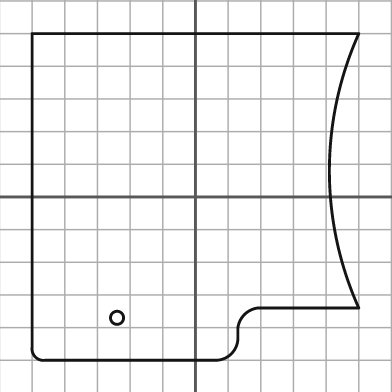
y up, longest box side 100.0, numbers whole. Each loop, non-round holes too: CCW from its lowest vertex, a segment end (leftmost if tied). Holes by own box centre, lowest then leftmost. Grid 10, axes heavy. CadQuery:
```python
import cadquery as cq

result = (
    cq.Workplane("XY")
    .moveTo(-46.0, -50.0)
    .lineTo(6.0, -50.0)
    .threePointArc((11.0, -48.0), (13.0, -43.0))
    .lineTo(13.0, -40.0)
    .threePointArc((15.0, -36.0), (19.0, -34.0))
    .lineTo(50.0, -34.0)
    .threePointArc((41.0, 8.0), (50.0, 50.0))
    .lineTo(-50.0, 50.0)
    .lineTo(-50.0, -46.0)
    .threePointArc((-49.0, -49.0), (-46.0, -50.0))
    .close()
    .moveTo(-24.0, -37.0)
    .circle(2.0)
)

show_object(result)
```